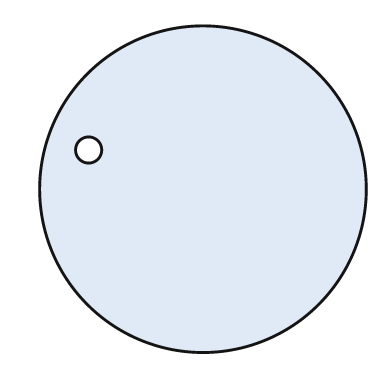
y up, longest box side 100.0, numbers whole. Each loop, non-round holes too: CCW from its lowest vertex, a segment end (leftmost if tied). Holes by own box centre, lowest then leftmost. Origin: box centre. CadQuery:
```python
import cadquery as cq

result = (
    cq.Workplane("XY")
    .moveTo(0.0, 0.0)
    .circle(50.0)
    .moveTo(-35.0, 12.0)
    .circle(4.0)
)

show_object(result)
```